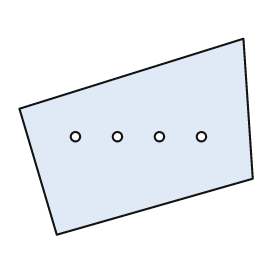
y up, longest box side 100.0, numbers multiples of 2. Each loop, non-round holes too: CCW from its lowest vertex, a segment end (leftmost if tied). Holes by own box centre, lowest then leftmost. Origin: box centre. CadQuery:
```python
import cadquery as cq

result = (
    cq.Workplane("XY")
    .moveTo(-34.0, -42.0)
    .lineTo(50.0, -18.0)
    .lineTo(46.0, 42.0)
    .lineTo(-50.0, 12.0)
    .close()
    .moveTo(-26.0, 0.0)
    .circle(2.0)
    .moveTo(-8.0, 0.0)
    .circle(2.0)
    .moveTo(10.0, 0.0)
    .circle(2.0)
    .moveTo(28.0, 0.0)
    .circle(2.0)
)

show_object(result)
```